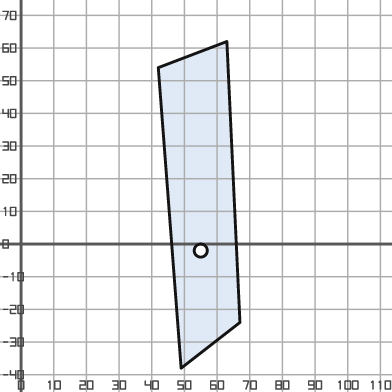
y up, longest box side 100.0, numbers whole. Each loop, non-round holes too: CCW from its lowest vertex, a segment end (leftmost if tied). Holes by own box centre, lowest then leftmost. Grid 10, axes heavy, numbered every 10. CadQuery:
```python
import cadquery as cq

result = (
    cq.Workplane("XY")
    .moveTo(49.0, -38.0)
    .lineTo(67.0, -24.0)
    .lineTo(63.0, 62.0)
    .lineTo(42.0, 54.0)
    .close()
    .moveTo(55.0, -2.0)
    .circle(2.0)
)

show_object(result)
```